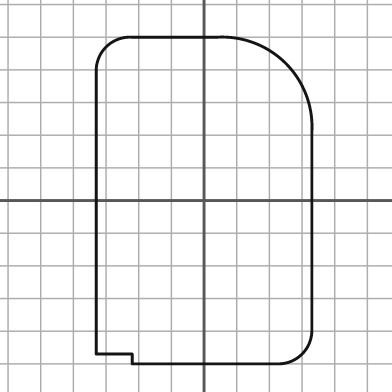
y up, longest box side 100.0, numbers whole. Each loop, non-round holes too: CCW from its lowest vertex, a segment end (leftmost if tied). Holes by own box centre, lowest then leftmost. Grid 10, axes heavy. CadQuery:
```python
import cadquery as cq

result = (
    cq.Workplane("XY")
    .moveTo(-22.0, -50.0)
    .lineTo(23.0, -50.0)
    .threePointArc((30.0, -47.0), (33.0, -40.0))
    .lineTo(33.0, 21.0)
    .threePointArc((25.0, 42.0), (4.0, 50.0))
    .lineTo(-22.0, 50.0)
    .threePointArc((-30.0, 47.0), (-33.0, 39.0))
    .lineTo(-33.0, -47.0)
    .lineTo(-22.0, -47.0)
    .close()
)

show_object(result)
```